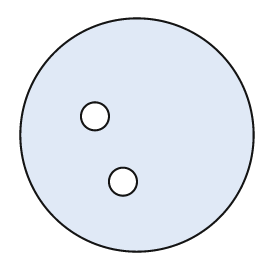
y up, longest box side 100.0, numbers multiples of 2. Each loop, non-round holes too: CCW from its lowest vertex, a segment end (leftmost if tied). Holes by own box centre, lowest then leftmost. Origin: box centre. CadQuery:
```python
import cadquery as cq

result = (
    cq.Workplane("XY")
    .moveTo(0.0, 0.0)
    .circle(50.0)
    .moveTo(-6.0, -20.0)
    .circle(6.0)
    .moveTo(-18.0, 8.0)
    .circle(6.0)
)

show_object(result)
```